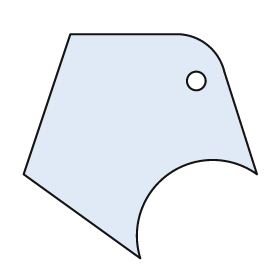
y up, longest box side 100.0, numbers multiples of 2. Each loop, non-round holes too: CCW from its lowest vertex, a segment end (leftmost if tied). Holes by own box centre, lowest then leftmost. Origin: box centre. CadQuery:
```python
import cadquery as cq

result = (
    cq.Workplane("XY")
    .moveTo(0.0, -48.0)
    .threePointArc((12.0, -12.0), (50.0, -12.0))
    .lineTo(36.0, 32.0)
    .threePointArc((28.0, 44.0), (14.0, 48.0))
    .lineTo(-30.0, 48.0)
    .lineTo(-50.0, -12.0)
    .close()
    .moveTo(24.0, 28.0)
    .circle(4.0)
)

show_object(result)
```